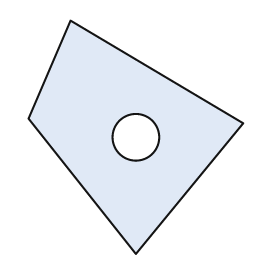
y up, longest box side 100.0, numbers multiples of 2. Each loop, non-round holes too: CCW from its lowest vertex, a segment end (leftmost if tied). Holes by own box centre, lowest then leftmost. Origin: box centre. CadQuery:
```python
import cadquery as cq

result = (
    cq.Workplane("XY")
    .moveTo(0.0, -50.0)
    .lineTo(46.0, 6.0)
    .lineTo(-28.0, 50.0)
    .lineTo(-46.0, 8.0)
    .close()
    .moveTo(0.0, 0.0)
    .circle(10.0)
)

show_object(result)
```